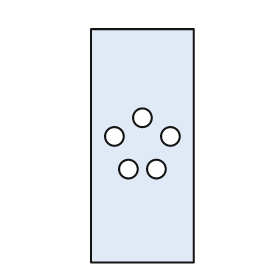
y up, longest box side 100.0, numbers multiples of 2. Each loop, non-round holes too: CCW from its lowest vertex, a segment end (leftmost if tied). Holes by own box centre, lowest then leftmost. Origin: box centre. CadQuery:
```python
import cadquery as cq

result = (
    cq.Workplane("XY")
    .moveTo(-22.0, -50.0)
    .lineTo(22.0, -50.0)
    .lineTo(22.0, 50.0)
    .lineTo(-22.0, 50.0)
    .close()
    .moveTo(-6.0, -10.0)
    .circle(4.0)
    .moveTo(6.0, -10.0)
    .circle(4.0)
    .moveTo(-12.0, 4.0)
    .circle(4.0)
    .moveTo(12.0, 4.0)
    .circle(4.0)
    .moveTo(0.0, 12.0)
    .circle(4.0)
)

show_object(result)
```